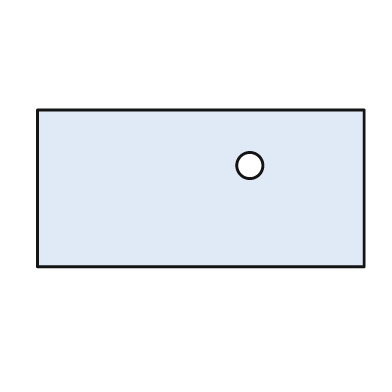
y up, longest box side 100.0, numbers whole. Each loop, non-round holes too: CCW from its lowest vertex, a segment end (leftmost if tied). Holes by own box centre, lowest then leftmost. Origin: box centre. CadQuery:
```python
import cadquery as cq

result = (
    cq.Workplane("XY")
    .moveTo(-50.0, -24.0)
    .lineTo(50.0, -24.0)
    .lineTo(50.0, 24.0)
    .lineTo(-50.0, 24.0)
    .close()
    .moveTo(15.0, 7.0)
    .circle(4.0)
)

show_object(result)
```